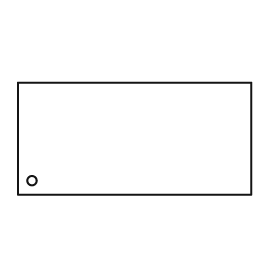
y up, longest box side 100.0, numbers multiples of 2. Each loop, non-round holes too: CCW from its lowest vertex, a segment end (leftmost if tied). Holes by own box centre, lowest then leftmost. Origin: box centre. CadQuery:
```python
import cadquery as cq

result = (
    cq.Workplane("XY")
    .moveTo(-50.0, -24.0)
    .lineTo(50.0, -24.0)
    .lineTo(50.0, 24.0)
    .lineTo(-50.0, 24.0)
    .close()
    .moveTo(-44.0, -18.0)
    .circle(2.0)
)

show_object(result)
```